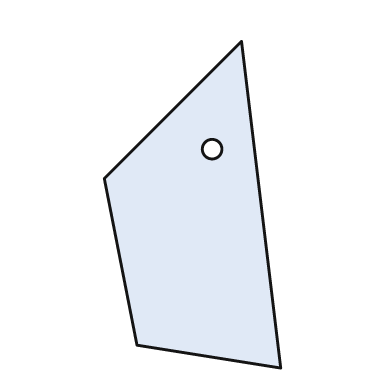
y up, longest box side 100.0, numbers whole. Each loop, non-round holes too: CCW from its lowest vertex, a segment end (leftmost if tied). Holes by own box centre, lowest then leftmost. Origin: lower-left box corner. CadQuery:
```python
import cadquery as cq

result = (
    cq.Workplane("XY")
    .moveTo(54.0, 0.0)
    .lineTo(42.0, 100.0)
    .lineTo(0.0, 58.0)
    .lineTo(10.0, 7.0)
    .close()
    .moveTo(33.0, 67.0)
    .circle(3.0)
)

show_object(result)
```